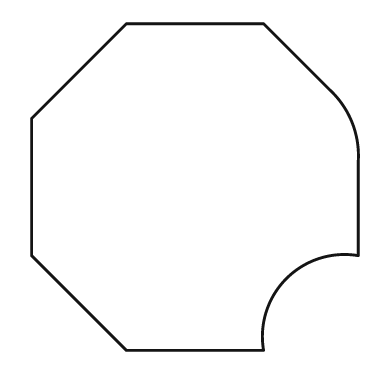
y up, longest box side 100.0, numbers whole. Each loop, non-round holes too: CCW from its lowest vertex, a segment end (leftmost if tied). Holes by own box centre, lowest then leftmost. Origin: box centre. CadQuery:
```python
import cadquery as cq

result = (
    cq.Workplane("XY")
    .moveTo(-21.0, -50.0)
    .lineTo(21.0, -50.0)
    .threePointArc((28.0, -28.0), (50.0, -21.0))
    .lineTo(50.0, 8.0)
    .threePointArc((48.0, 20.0), (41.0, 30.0))
    .lineTo(21.0, 50.0)
    .lineTo(-21.0, 50.0)
    .lineTo(-50.0, 21.0)
    .lineTo(-50.0, -21.0)
    .close()
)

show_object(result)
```